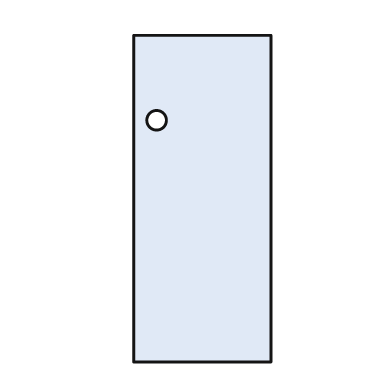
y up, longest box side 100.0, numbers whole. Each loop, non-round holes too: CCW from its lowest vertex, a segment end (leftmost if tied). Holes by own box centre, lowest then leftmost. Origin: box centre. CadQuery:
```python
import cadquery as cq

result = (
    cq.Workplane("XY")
    .moveTo(-21.0, -50.0)
    .lineTo(21.0, -50.0)
    .lineTo(21.0, 50.0)
    .lineTo(-21.0, 50.0)
    .close()
    .moveTo(-14.0, 24.0)
    .circle(3.0)
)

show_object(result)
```